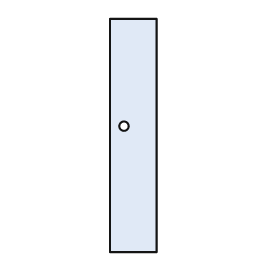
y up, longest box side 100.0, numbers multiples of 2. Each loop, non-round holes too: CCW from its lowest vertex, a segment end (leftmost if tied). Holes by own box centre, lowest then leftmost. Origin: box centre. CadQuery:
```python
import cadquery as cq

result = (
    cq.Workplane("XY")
    .moveTo(-10.0, -50.0)
    .lineTo(10.0, -50.0)
    .lineTo(10.0, 50.0)
    .lineTo(-10.0, 50.0)
    .close()
    .moveTo(-4.0, 4.0)
    .circle(2.0)
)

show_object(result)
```